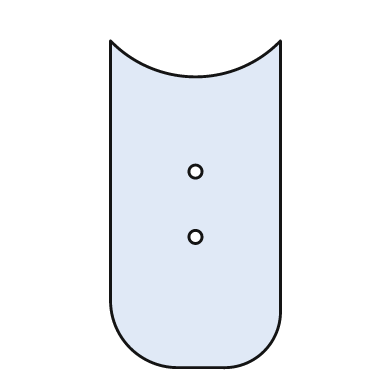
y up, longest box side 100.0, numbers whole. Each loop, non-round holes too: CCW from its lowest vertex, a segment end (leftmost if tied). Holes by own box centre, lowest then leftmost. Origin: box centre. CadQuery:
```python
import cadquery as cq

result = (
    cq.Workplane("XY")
    .moveTo(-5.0, -50.0)
    .lineTo(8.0, -50.0)
    .threePointArc((21.0, -45.0), (26.0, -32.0))
    .lineTo(26.0, 50.0)
    .threePointArc((0.0, 39.0), (-26.0, 50.0))
    .lineTo(-26.0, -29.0)
    .threePointArc((-20.0, -44.0), (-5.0, -50.0))
    .close()
    .moveTo(0.0, -10.0)
    .circle(2.0)
    .moveTo(0.0, 10.0)
    .circle(2.0)
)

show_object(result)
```